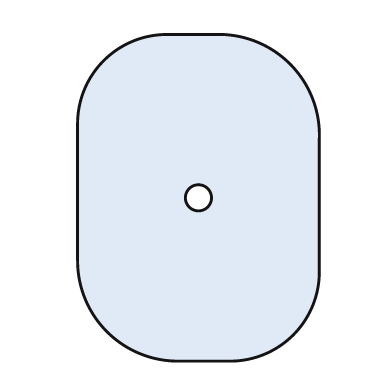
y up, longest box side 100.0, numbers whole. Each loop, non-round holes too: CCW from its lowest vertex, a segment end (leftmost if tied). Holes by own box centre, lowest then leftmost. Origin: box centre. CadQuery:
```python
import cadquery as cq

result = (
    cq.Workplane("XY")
    .moveTo(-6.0, -50.0)
    .lineTo(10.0, -50.0)
    .threePointArc((29.0, -42.0), (37.0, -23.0))
    .lineTo(37.0, 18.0)
    .threePointArc((28.0, 41.0), (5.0, 50.0))
    .lineTo(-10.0, 50.0)
    .threePointArc((-29.0, 42.0), (-37.0, 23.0))
    .lineTo(-37.0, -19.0)
    .threePointArc((-28.0, -41.0), (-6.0, -50.0))
    .close()
    .moveTo(0.0, 0.0)
    .circle(4.0)
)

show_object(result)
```